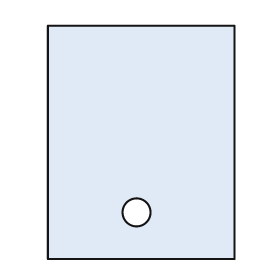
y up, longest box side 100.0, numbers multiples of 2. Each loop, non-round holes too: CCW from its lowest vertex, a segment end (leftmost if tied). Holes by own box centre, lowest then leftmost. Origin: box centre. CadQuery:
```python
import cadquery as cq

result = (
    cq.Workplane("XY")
    .moveTo(-40.0, -50.0)
    .lineTo(40.0, -50.0)
    .lineTo(40.0, 50.0)
    .lineTo(-40.0, 50.0)
    .close()
    .moveTo(-2.0, -30.0)
    .circle(6.0)
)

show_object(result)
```